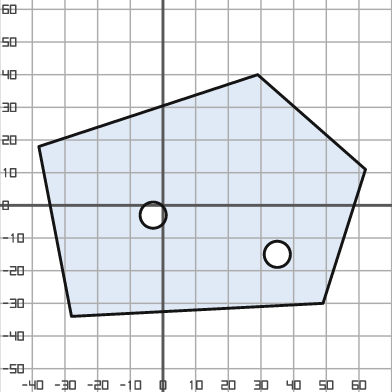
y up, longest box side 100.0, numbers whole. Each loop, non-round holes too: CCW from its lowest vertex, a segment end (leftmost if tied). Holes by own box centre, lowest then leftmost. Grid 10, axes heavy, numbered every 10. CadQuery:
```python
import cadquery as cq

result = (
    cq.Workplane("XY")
    .moveTo(-28.0, -34.0)
    .lineTo(49.0, -30.0)
    .lineTo(62.0, 11.0)
    .lineTo(29.0, 40.0)
    .lineTo(-38.0, 18.0)
    .close()
    .moveTo(35.0, -15.0)
    .circle(4.0)
    .moveTo(-3.0, -3.0)
    .circle(4.0)
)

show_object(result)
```